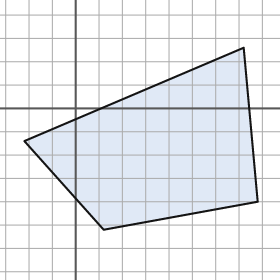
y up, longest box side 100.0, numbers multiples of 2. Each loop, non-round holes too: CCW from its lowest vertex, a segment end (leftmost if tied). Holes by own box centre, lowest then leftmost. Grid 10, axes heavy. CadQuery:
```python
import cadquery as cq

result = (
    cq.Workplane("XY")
    .moveTo(12.0, -52.0)
    .lineTo(78.0, -40.0)
    .lineTo(72.0, 26.0)
    .lineTo(-22.0, -14.0)
    .close()
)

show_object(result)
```